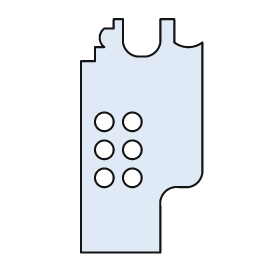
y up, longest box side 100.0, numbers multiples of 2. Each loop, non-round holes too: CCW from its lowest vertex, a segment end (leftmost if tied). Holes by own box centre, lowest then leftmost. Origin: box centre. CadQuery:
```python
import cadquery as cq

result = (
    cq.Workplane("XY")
    .moveTo(-26.0, -50.0)
    .lineTo(8.0, -50.0)
    .lineTo(8.0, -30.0)
    .threePointArc((10.0, -24.0), (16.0, -22.0))
    .lineTo(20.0, -22.0)
    .threePointArc((24.0, -20.0), (26.0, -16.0))
    .lineTo(26.0, 40.0)
    .threePointArc((20.0, 38.0), (14.0, 40.0))
    .lineTo(14.0, 50.0)
    .lineTo(8.0, 50.0)
    .lineTo(8.0, 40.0)
    .threePointArc((6.0, 36.0), (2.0, 34.0))
    .lineTo(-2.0, 34.0)
    .threePointArc((-6.0, 36.0), (-8.0, 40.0))
    .lineTo(-8.0, 50.0)
    .lineTo(-12.0, 50.0)
    .lineTo(-12.0, 46.0)
    .lineTo(-16.0, 46.0)
    .threePointArc((-18.0, 42.0), (-16.0, 38.0))
    .lineTo(-20.0, 38.0)
    .lineTo(-20.0, 32.0)
    .lineTo(-26.0, 32.0)
    .close()
    .moveTo(-16.0, -18.0)
    .circle(4.0)
    .moveTo(-4.0, -18.0)
    .circle(4.0)
    .moveTo(-16.0, -6.0)
    .circle(4.0)
    .moveTo(-4.0, -6.0)
    .circle(4.0)
    .moveTo(-16.0, 6.0)
    .circle(4.0)
    .moveTo(-4.0, 6.0)
    .circle(4.0)
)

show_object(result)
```